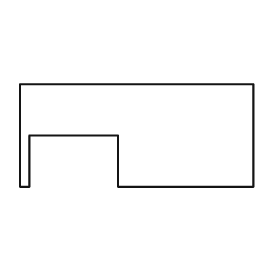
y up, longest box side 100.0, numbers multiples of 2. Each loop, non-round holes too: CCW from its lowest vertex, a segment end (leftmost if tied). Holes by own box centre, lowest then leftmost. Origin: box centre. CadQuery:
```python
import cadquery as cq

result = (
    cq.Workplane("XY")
    .moveTo(-50.0, -22.0)
    .lineTo(-46.0, -22.0)
    .lineTo(-46.0, 0.0)
    .lineTo(-8.0, 0.0)
    .lineTo(-8.0, -22.0)
    .lineTo(50.0, -22.0)
    .lineTo(50.0, 22.0)
    .lineTo(-50.0, 22.0)
    .close()
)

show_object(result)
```